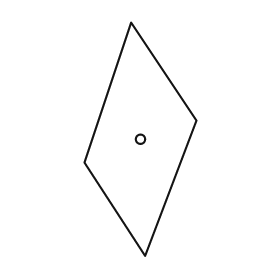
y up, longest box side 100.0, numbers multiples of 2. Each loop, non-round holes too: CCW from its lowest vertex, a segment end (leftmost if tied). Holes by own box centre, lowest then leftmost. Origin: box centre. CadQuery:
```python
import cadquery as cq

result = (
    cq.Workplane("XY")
    .moveTo(2.0, -50.0)
    .lineTo(24.0, 8.0)
    .lineTo(-4.0, 50.0)
    .lineTo(-24.0, -10.0)
    .close()
    .moveTo(0.0, 0.0)
    .circle(2.0)
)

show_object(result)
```